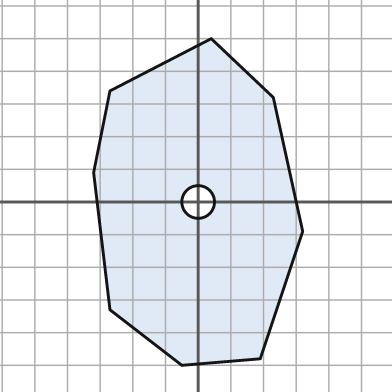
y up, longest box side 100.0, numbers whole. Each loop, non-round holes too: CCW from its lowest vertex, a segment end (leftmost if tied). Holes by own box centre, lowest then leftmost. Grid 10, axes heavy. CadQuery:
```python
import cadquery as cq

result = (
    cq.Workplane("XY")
    .moveTo(-5.0, -50.0)
    .lineTo(19.0, -48.0)
    .lineTo(32.0, -9.0)
    .lineTo(23.0, 32.0)
    .lineTo(4.0, 50.0)
    .lineTo(-27.0, 34.0)
    .lineTo(-32.0, 9.0)
    .lineTo(-27.0, -33.0)
    .close()
    .moveTo(0.0, 0.0)
    .circle(5.0)
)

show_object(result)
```